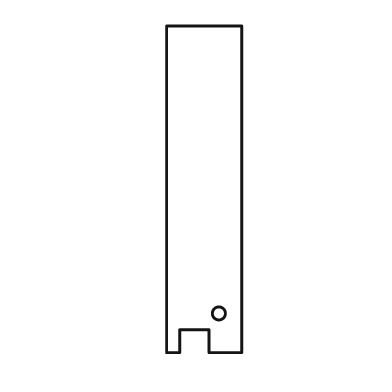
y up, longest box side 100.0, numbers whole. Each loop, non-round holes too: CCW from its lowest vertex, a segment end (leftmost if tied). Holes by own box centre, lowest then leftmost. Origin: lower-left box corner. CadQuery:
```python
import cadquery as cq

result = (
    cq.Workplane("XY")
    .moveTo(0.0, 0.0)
    .lineTo(4.0, 0.0)
    .lineTo(4.0, 7.0)
    .lineTo(13.0, 7.0)
    .lineTo(13.0, 0.0)
    .lineTo(23.0, 0.0)
    .lineTo(23.0, 100.0)
    .lineTo(0.0, 100.0)
    .close()
    .moveTo(16.0, 12.0)
    .circle(2.0)
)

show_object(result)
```